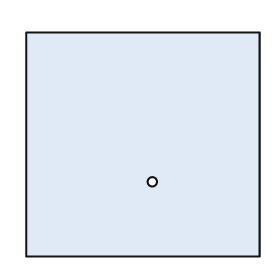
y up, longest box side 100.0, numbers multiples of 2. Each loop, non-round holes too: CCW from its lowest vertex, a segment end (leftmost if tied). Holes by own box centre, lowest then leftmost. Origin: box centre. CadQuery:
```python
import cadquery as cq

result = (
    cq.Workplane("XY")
    .moveTo(-50.0, -48.0)
    .lineTo(50.0, -48.0)
    .lineTo(50.0, 48.0)
    .lineTo(-50.0, 48.0)
    .close()
    .moveTo(4.0, -16.0)
    .circle(2.0)
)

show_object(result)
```